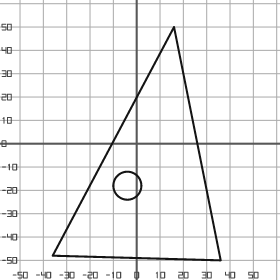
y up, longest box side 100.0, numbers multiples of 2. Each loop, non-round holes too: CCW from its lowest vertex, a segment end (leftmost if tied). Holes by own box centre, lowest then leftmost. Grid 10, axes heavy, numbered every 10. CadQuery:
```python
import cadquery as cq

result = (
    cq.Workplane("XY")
    .moveTo(36.0, -50.0)
    .lineTo(16.0, 50.0)
    .lineTo(-36.0, -48.0)
    .close()
    .moveTo(-4.0, -18.0)
    .circle(6.0)
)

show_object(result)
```